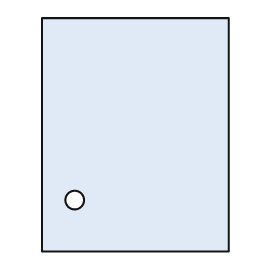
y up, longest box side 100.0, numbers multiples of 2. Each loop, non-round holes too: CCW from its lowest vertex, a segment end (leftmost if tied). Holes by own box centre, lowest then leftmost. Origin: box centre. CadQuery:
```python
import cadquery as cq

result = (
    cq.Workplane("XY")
    .moveTo(-40.0, -50.0)
    .lineTo(40.0, -50.0)
    .lineTo(40.0, 50.0)
    .lineTo(-40.0, 50.0)
    .close()
    .moveTo(-26.0, -28.0)
    .circle(4.0)
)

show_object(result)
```